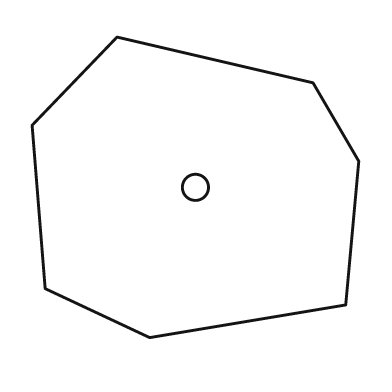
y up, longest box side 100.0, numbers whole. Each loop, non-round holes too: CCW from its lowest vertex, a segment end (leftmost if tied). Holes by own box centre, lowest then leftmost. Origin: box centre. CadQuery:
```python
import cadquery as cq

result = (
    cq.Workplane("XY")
    .moveTo(-14.0, -46.0)
    .lineTo(46.0, -36.0)
    .lineTo(50.0, 8.0)
    .lineTo(36.0, 32.0)
    .lineTo(-24.0, 46.0)
    .lineTo(-50.0, 19.0)
    .lineTo(-46.0, -31.0)
    .close()
    .moveTo(0.0, 0.0)
    .circle(4.0)
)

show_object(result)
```